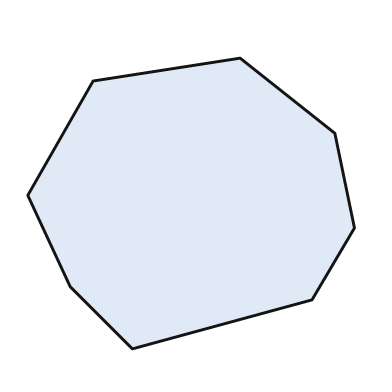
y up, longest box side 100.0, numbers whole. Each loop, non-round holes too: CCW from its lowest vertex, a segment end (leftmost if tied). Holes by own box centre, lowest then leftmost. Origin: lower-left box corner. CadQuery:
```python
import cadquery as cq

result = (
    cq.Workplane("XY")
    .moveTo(32.0, 0.0)
    .lineTo(87.0, 15.0)
    .lineTo(100.0, 37.0)
    .lineTo(94.0, 66.0)
    .lineTo(65.0, 89.0)
    .lineTo(20.0, 82.0)
    .lineTo(0.0, 47.0)
    .lineTo(13.0, 19.0)
    .close()
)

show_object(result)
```